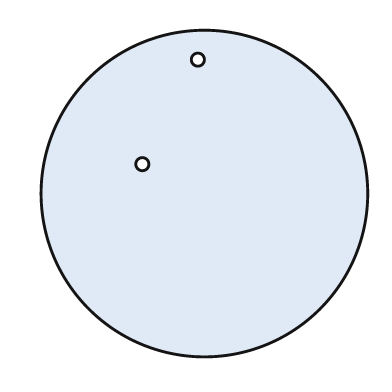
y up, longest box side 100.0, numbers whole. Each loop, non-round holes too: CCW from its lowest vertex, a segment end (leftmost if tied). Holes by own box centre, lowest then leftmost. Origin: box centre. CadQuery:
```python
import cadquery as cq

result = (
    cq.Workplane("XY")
    .moveTo(0.0, 0.0)
    .circle(50.0)
    .moveTo(-19.0, 9.0)
    .circle(2.0)
    .moveTo(-2.0, 41.0)
    .circle(2.0)
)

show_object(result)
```